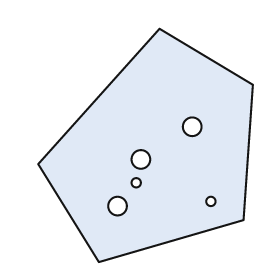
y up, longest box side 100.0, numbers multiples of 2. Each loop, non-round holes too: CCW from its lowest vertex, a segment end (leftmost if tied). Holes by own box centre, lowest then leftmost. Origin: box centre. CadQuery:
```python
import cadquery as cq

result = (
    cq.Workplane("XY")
    .moveTo(-20.0, -50.0)
    .lineTo(42.0, -32.0)
    .lineTo(46.0, 26.0)
    .lineTo(6.0, 50.0)
    .lineTo(-46.0, -8.0)
    .close()
    .moveTo(-12.0, -26.0)
    .circle(4.0)
    .moveTo(28.0, -24.0)
    .circle(2.0)
    .moveTo(-4.0, -16.0)
    .circle(2.0)
    .moveTo(-2.0, -6.0)
    .circle(4.0)
    .moveTo(20.0, 8.0)
    .circle(4.0)
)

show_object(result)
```